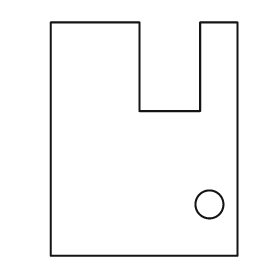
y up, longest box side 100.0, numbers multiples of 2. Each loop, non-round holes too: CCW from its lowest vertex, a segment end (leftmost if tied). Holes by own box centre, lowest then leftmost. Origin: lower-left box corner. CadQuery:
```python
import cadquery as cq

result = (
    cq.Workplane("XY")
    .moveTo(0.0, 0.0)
    .lineTo(80.0, 0.0)
    .lineTo(80.0, 100.0)
    .lineTo(64.0, 100.0)
    .lineTo(64.0, 62.0)
    .lineTo(38.0, 62.0)
    .lineTo(38.0, 100.0)
    .lineTo(0.0, 100.0)
    .close()
    .moveTo(68.0, 22.0)
    .circle(6.0)
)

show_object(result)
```